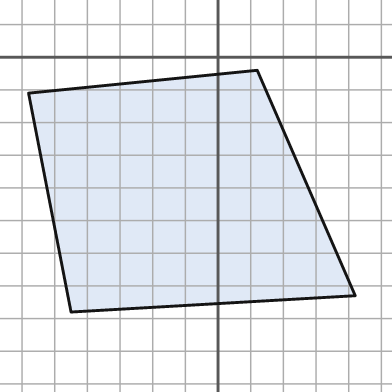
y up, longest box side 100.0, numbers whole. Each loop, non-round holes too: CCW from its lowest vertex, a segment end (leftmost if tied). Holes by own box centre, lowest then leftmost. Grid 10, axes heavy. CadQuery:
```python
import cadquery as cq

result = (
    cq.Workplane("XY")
    .moveTo(-45.0, -78.0)
    .lineTo(42.0, -73.0)
    .lineTo(12.0, -4.0)
    .lineTo(-58.0, -11.0)
    .close()
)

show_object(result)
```